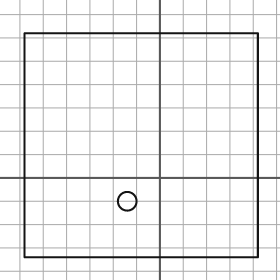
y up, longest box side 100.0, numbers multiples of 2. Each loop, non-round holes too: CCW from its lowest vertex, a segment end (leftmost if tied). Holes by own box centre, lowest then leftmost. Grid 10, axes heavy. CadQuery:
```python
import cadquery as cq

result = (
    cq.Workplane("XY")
    .moveTo(-58.0, -34.0)
    .lineTo(42.0, -34.0)
    .lineTo(42.0, 62.0)
    .lineTo(-58.0, 62.0)
    .close()
    .moveTo(-14.0, -10.0)
    .circle(4.0)
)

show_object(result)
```